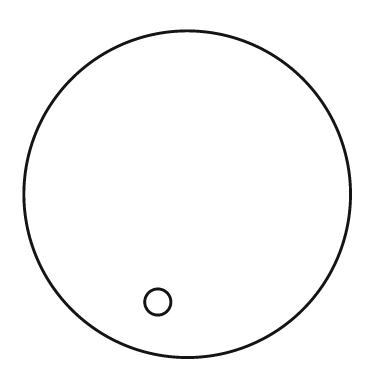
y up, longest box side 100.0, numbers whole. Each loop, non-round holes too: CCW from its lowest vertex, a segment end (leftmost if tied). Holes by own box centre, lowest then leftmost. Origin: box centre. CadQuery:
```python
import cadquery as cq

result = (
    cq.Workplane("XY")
    .moveTo(0.0, 0.0)
    .circle(50.0)
    .moveTo(-9.0, -33.0)
    .circle(4.0)
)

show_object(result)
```